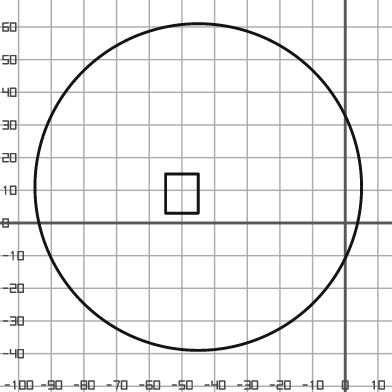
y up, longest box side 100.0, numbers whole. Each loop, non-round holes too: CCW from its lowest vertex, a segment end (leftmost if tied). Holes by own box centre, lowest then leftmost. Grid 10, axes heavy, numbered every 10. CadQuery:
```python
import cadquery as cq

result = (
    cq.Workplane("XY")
    .moveTo(-45.0, 11.0)
    .circle(50.0)
    .moveTo(-55.0, 3.0)
    .lineTo(-45.0, 3.0)
    .lineTo(-45.0, 15.0)
    .lineTo(-55.0, 15.0)
    .close()
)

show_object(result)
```